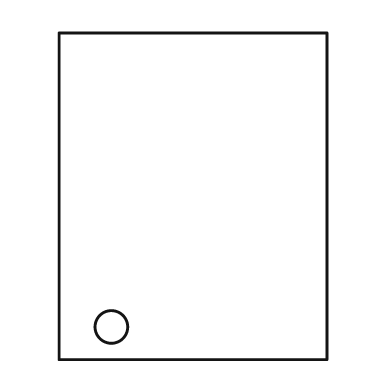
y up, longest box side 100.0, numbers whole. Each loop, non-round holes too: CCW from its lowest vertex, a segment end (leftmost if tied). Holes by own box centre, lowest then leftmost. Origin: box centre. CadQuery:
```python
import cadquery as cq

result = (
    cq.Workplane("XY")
    .moveTo(-41.0, -50.0)
    .lineTo(41.0, -50.0)
    .lineTo(41.0, 50.0)
    .lineTo(-41.0, 50.0)
    .close()
    .moveTo(-25.0, -40.0)
    .circle(5.0)
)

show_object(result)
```